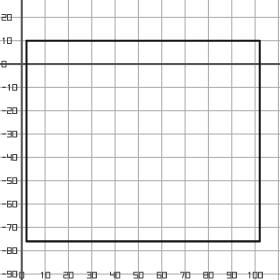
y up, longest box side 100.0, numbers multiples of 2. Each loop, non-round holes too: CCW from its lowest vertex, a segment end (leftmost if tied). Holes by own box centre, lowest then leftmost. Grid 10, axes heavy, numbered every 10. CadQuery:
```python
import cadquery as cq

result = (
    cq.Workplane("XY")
    .moveTo(2.0, -76.0)
    .lineTo(102.0, -76.0)
    .lineTo(102.0, 10.0)
    .lineTo(2.0, 10.0)
    .close()
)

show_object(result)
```